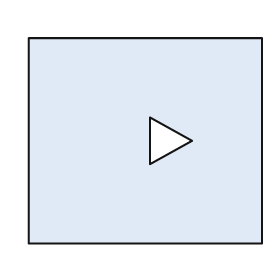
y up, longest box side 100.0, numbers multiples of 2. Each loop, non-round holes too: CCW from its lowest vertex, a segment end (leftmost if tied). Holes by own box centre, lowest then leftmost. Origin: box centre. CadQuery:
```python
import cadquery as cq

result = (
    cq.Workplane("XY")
    .moveTo(-50.0, -44.0)
    .lineTo(50.0, -44.0)
    .lineTo(50.0, 44.0)
    .lineTo(-50.0, 44.0)
    .close()
    .moveTo(2.0, -10.0)
    .lineTo(20.0, 0.0)
    .lineTo(2.0, 10.0)
    .close()
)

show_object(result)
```